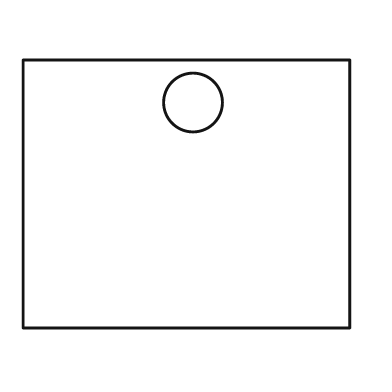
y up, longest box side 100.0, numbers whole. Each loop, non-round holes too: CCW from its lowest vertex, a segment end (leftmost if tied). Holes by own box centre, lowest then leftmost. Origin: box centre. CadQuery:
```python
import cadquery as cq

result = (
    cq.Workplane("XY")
    .moveTo(-50.0, -41.0)
    .lineTo(50.0, -41.0)
    .lineTo(50.0, 41.0)
    .lineTo(-50.0, 41.0)
    .close()
    .moveTo(2.0, 28.0)
    .circle(9.0)
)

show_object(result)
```